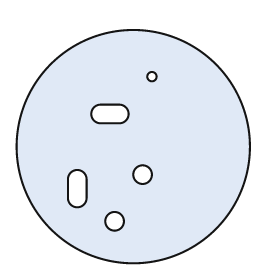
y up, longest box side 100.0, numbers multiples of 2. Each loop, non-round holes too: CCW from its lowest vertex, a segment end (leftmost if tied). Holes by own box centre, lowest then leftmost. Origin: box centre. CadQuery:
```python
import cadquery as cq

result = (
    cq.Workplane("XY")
    .moveTo(0.0, 0.0)
    .circle(50.0)
    .moveTo(-8.0, -32.0)
    .circle(4.0)
    .moveTo(-28.0, -22.0)
    .threePointArc((-24.0, -26.0), (-20.0, -22.0))
    .lineTo(-20.0, -14.0)
    .threePointArc((-24.0, -10.0), (-28.0, -14.0))
    .close()
    .moveTo(4.0, -12.0)
    .circle(4.0)
    .moveTo(-14.0, 10.0)
    .lineTo(-6.0, 10.0)
    .threePointArc((-2.0, 14.0), (-6.0, 18.0))
    .lineTo(-14.0, 18.0)
    .threePointArc((-18.0, 14.0), (-14.0, 10.0))
    .close()
    .moveTo(8.0, 30.0)
    .circle(2.0)
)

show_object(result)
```